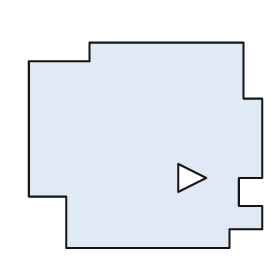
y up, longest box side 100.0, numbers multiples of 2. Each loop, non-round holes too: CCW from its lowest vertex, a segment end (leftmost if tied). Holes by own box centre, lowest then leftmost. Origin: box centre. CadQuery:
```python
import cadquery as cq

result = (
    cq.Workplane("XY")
    .moveTo(-34.0, -44.0)
    .lineTo(36.0, -44.0)
    .lineTo(36.0, -36.0)
    .lineTo(50.0, -36.0)
    .lineTo(50.0, -26.0)
    .lineTo(40.0, -26.0)
    .lineTo(40.0, -14.0)
    .lineTo(50.0, -14.0)
    .lineTo(50.0, 20.0)
    .lineTo(42.0, 20.0)
    .lineTo(42.0, 44.0)
    .lineTo(-24.0, 44.0)
    .lineTo(-24.0, 36.0)
    .lineTo(-50.0, 36.0)
    .lineTo(-50.0, -22.0)
    .lineTo(-34.0, -22.0)
    .close()
    .moveTo(14.0, -20.0)
    .lineTo(26.0, -14.0)
    .lineTo(14.0, -8.0)
    .close()
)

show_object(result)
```